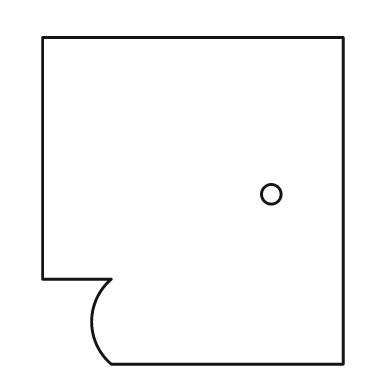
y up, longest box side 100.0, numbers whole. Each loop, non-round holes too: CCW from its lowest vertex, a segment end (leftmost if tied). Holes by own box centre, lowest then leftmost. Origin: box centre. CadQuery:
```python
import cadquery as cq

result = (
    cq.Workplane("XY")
    .moveTo(-25.0, -50.0)
    .lineTo(46.0, -50.0)
    .lineTo(46.0, 50.0)
    .lineTo(-46.0, 50.0)
    .lineTo(-46.0, -24.0)
    .lineTo(-25.0, -24.0)
    .threePointArc((-31.0, -37.0), (-25.0, -50.0))
    .close()
    .moveTo(24.0, 2.0)
    .circle(3.0)
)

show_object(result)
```